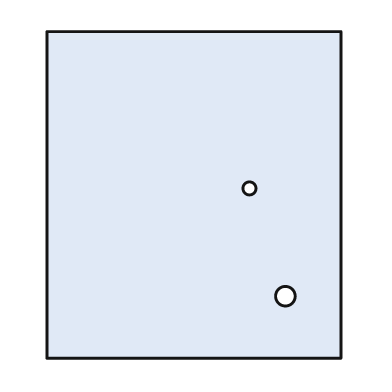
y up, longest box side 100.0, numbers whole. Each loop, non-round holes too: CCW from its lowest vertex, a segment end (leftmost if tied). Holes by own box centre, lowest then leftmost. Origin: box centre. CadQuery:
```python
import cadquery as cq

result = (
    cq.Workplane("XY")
    .moveTo(-45.0, -50.0)
    .lineTo(45.0, -50.0)
    .lineTo(45.0, 50.0)
    .lineTo(-45.0, 50.0)
    .close()
    .moveTo(28.0, -31.0)
    .circle(3.0)
    .moveTo(17.0, 2.0)
    .circle(2.0)
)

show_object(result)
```